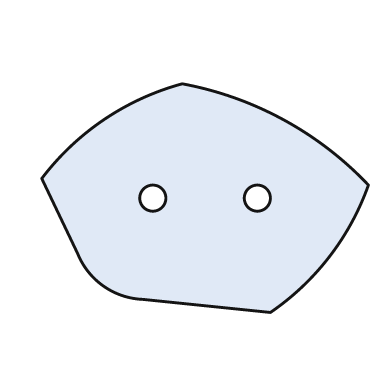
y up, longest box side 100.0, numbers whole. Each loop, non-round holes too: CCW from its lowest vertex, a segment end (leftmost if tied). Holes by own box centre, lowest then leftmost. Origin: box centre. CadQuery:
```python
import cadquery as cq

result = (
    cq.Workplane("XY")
    .moveTo(20.0, -35.0)
    .threePointArc((38.0, -18.0), (50.0, 4.0))
    .threePointArc((24.0, 24.0), (-7.0, 35.0))
    .threePointArc((-31.0, 24.0), (-50.0, 6.0))
    .lineTo(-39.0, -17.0)
    .threePointArc((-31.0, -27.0), (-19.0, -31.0))
    .close()
    .moveTo(-16.0, 0.0)
    .circle(4.0)
    .moveTo(16.0, 0.0)
    .circle(4.0)
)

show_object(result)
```